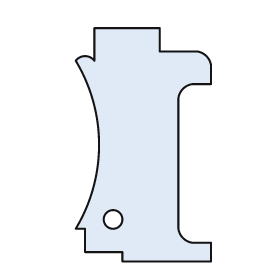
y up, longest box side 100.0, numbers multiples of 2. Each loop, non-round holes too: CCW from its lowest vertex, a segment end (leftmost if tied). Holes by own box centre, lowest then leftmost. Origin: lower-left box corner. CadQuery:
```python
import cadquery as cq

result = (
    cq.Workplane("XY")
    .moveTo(20.0, 0.0)
    .lineTo(58.0, 0.0)
    .lineTo(58.0, 8.0)
    .lineTo(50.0, 8.0)
    .threePointArc((46.0, 10.0), (44.0, 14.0))
    .lineTo(44.0, 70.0)
    .threePointArc((46.0, 74.0), (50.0, 76.0))
    .lineTo(58.0, 76.0)
    .lineTo(58.0, 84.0)
    .threePointArc((56.0, 88.0), (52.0, 90.0))
    .lineTo(36.0, 90.0)
    .lineTo(36.0, 100.0)
    .lineTo(8.0, 100.0)
    .lineTo(8.0, 86.0)
    .threePointArc((4.0, 88.0), (0.0, 86.0))
    .threePointArc((10.0, 50.0), (0.0, 14.0))
    .lineTo(4.0, 14.0)
    .lineTo(4.0, 4.0)
    .lineTo(20.0, 4.0)
    .close()
    .moveTo(16.0, 18.0)
    .circle(4.0)
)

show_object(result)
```